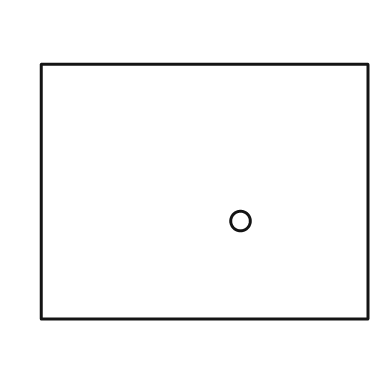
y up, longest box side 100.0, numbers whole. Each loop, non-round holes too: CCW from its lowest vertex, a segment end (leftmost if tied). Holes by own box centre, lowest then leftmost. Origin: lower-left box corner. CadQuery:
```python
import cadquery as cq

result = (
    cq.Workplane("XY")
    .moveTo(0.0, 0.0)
    .lineTo(100.0, 0.0)
    .lineTo(100.0, 78.0)
    .lineTo(0.0, 78.0)
    .close()
    .moveTo(61.0, 30.0)
    .circle(3.0)
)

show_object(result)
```